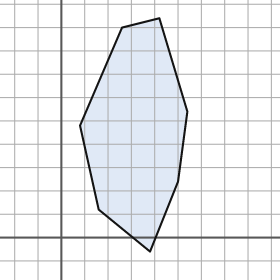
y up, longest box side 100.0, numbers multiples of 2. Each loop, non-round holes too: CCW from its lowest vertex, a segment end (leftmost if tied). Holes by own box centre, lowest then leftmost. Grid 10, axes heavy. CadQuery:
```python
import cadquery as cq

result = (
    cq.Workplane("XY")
    .moveTo(38.0, -6.0)
    .lineTo(50.0, 24.0)
    .lineTo(54.0, 54.0)
    .lineTo(42.0, 94.0)
    .lineTo(26.0, 90.0)
    .lineTo(8.0, 48.0)
    .lineTo(16.0, 12.0)
    .close()
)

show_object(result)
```